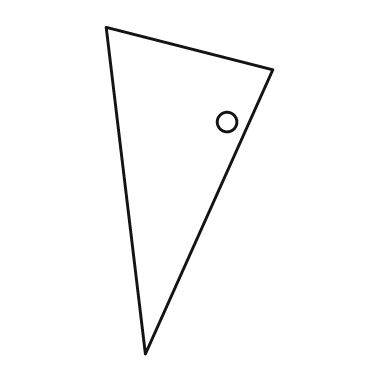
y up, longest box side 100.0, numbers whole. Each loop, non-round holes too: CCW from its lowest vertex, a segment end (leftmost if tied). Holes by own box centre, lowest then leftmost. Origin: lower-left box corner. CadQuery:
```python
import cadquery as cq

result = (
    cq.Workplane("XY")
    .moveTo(12.0, 0.0)
    .lineTo(51.0, 87.0)
    .lineTo(0.0, 100.0)
    .close()
    .moveTo(37.0, 71.0)
    .circle(3.0)
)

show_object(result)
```